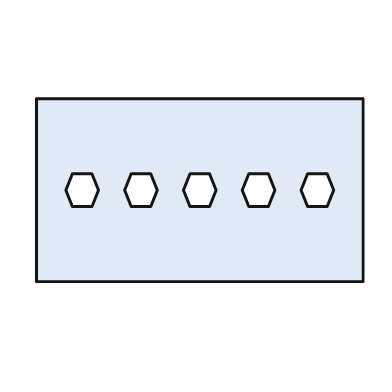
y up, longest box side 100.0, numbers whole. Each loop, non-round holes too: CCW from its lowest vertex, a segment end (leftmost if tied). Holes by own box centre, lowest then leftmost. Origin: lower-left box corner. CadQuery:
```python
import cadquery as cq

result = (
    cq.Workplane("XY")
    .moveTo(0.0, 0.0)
    .lineTo(100.0, 0.0)
    .lineTo(100.0, 56.0)
    .lineTo(0.0, 56.0)
    .close()
    .moveTo(11.0, 23.0)
    .lineTo(17.0, 23.0)
    .lineTo(19.0, 28.0)
    .lineTo(17.0, 33.0)
    .lineTo(11.0, 33.0)
    .lineTo(9.0, 28.0)
    .close()
    .moveTo(29.0, 23.0)
    .lineTo(35.0, 23.0)
    .lineTo(37.0, 28.0)
    .lineTo(35.0, 33.0)
    .lineTo(29.0, 33.0)
    .lineTo(27.0, 28.0)
    .close()
    .moveTo(47.0, 23.0)
    .lineTo(53.0, 23.0)
    .lineTo(55.0, 28.0)
    .lineTo(53.0, 33.0)
    .lineTo(47.0, 33.0)
    .lineTo(45.0, 28.0)
    .close()
    .moveTo(65.0, 23.0)
    .lineTo(71.0, 23.0)
    .lineTo(73.0, 28.0)
    .lineTo(71.0, 33.0)
    .lineTo(65.0, 33.0)
    .lineTo(63.0, 28.0)
    .close()
    .moveTo(83.0, 23.0)
    .lineTo(89.0, 23.0)
    .lineTo(91.0, 28.0)
    .lineTo(89.0, 33.0)
    .lineTo(83.0, 33.0)
    .lineTo(81.0, 28.0)
    .close()
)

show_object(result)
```